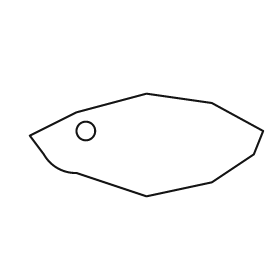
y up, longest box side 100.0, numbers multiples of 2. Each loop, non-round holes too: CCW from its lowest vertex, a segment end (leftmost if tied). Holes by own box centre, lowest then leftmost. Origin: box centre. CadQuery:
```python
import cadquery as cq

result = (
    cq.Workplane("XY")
    .moveTo(0.0, -22.0)
    .lineTo(28.0, -16.0)
    .lineTo(46.0, -4.0)
    .lineTo(50.0, 6.0)
    .lineTo(28.0, 18.0)
    .lineTo(0.0, 22.0)
    .lineTo(-30.0, 14.0)
    .lineTo(-50.0, 4.0)
    .lineTo(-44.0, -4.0)
    .threePointArc((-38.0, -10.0), (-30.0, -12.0))
    .close()
    .moveTo(-26.0, 6.0)
    .circle(4.0)
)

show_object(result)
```